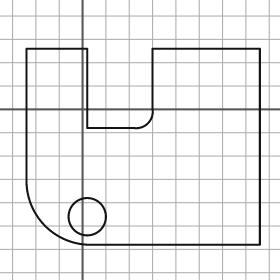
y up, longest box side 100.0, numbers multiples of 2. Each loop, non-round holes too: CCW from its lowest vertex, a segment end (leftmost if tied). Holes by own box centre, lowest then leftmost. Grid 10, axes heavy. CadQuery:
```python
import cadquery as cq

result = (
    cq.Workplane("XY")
    .moveTo(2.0, -58.0)
    .lineTo(76.0, -58.0)
    .lineTo(76.0, 26.0)
    .lineTo(30.0, 26.0)
    .lineTo(30.0, 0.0)
    .threePointArc((28.0, -6.0), (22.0, -8.0))
    .lineTo(2.0, -8.0)
    .lineTo(2.0, 26.0)
    .lineTo(-24.0, 26.0)
    .lineTo(-24.0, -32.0)
    .threePointArc((-16.0, -50.0), (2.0, -58.0))
    .close()
    .moveTo(2.0, -46.0)
    .circle(8.0)
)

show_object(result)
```